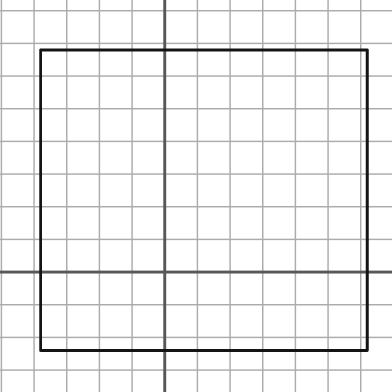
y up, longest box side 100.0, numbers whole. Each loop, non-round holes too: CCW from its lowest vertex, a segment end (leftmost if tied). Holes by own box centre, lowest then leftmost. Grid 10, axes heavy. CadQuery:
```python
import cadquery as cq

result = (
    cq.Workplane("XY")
    .moveTo(-38.0, -24.0)
    .lineTo(62.0, -24.0)
    .lineTo(62.0, 68.0)
    .lineTo(-38.0, 68.0)
    .close()
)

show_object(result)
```